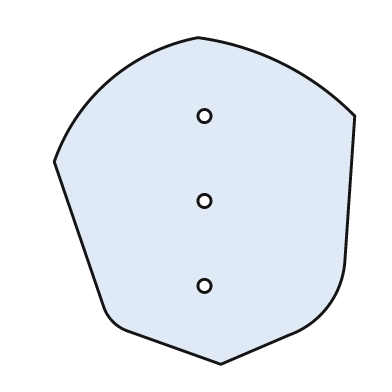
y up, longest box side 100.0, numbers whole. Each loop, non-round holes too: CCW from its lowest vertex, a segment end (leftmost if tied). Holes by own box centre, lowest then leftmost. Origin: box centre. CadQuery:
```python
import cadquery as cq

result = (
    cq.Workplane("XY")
    .moveTo(5.0, -50.0)
    .lineTo(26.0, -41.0)
    .threePointArc((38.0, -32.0), (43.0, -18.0))
    .lineTo(46.0, 26.0)
    .threePointArc((24.0, 42.0), (-2.0, 50.0))
    .threePointArc((-29.0, 37.0), (-46.0, 12.0))
    .lineTo(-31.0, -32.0)
    .threePointArc((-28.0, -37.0), (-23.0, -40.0))
    .close()
    .moveTo(0.0, -26.0)
    .circle(2.0)
    .moveTo(0.0, 0.0)
    .circle(2.0)
    .moveTo(0.0, 26.0)
    .circle(2.0)
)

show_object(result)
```